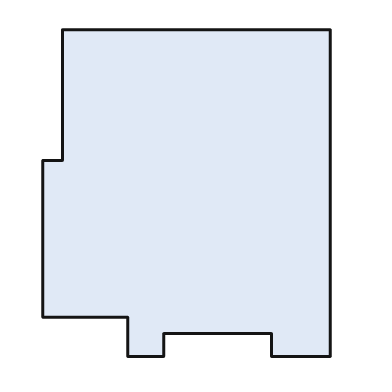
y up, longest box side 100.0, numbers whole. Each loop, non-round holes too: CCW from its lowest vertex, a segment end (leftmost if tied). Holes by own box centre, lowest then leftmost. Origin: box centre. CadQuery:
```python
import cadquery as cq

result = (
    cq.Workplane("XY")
    .moveTo(-18.0, -50.0)
    .lineTo(-7.0, -50.0)
    .lineTo(-7.0, -43.0)
    .lineTo(26.0, -43.0)
    .lineTo(26.0, -50.0)
    .lineTo(44.0, -50.0)
    .lineTo(44.0, 50.0)
    .lineTo(-38.0, 50.0)
    .lineTo(-38.0, 10.0)
    .lineTo(-44.0, 10.0)
    .lineTo(-44.0, -38.0)
    .lineTo(-18.0, -38.0)
    .close()
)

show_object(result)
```